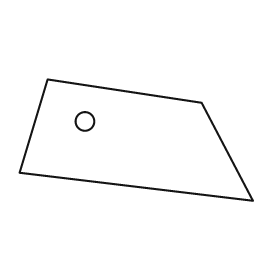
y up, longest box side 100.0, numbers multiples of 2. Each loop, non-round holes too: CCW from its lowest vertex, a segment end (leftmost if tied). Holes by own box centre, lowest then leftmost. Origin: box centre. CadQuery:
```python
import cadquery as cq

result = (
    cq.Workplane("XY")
    .moveTo(50.0, -26.0)
    .lineTo(28.0, 16.0)
    .lineTo(-38.0, 26.0)
    .lineTo(-50.0, -14.0)
    .close()
    .moveTo(-22.0, 8.0)
    .circle(4.0)
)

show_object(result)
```